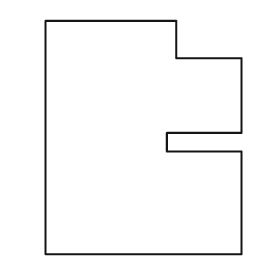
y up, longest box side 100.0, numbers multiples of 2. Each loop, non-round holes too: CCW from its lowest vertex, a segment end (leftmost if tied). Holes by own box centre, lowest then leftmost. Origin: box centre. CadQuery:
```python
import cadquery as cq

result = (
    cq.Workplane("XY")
    .moveTo(-42.0, -50.0)
    .lineTo(42.0, -50.0)
    .lineTo(42.0, -6.0)
    .lineTo(10.0, -6.0)
    .lineTo(10.0, 2.0)
    .lineTo(42.0, 2.0)
    .lineTo(42.0, 34.0)
    .lineTo(14.0, 34.0)
    .lineTo(14.0, 50.0)
    .lineTo(-42.0, 50.0)
    .close()
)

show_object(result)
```